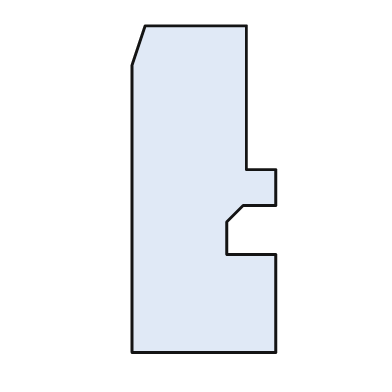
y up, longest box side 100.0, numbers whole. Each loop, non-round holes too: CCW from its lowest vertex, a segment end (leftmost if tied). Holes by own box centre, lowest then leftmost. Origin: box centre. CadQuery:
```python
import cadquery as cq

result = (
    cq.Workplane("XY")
    .moveTo(-22.0, -50.0)
    .lineTo(22.0, -50.0)
    .lineTo(22.0, -20.0)
    .lineTo(7.0, -20.0)
    .lineTo(7.0, -10.0)
    .lineTo(12.0, -5.0)
    .lineTo(22.0, -5.0)
    .lineTo(22.0, 6.0)
    .lineTo(13.0, 6.0)
    .lineTo(13.0, 50.0)
    .lineTo(-18.0, 50.0)
    .lineTo(-22.0, 38.0)
    .close()
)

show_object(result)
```